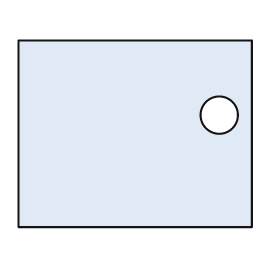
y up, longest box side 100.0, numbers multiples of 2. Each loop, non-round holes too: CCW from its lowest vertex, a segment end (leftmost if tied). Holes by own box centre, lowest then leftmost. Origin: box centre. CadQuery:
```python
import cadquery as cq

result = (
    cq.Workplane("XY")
    .moveTo(-50.0, -40.0)
    .lineTo(50.0, -40.0)
    .lineTo(50.0, 40.0)
    .lineTo(-50.0, 40.0)
    .close()
    .moveTo(36.0, 8.0)
    .circle(8.0)
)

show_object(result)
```